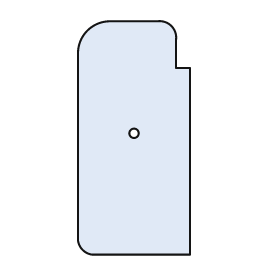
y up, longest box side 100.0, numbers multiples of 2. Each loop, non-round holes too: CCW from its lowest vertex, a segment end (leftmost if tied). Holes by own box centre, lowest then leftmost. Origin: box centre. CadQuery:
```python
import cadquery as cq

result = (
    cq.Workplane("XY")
    .moveTo(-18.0, -50.0)
    .lineTo(24.0, -50.0)
    .lineTo(24.0, 30.0)
    .lineTo(18.0, 30.0)
    .lineTo(18.0, 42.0)
    .threePointArc((16.0, 48.0), (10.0, 50.0))
    .lineTo(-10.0, 50.0)
    .threePointArc((-20.0, 46.0), (-24.0, 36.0))
    .lineTo(-24.0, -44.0)
    .threePointArc((-22.0, -48.0), (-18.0, -50.0))
    .close()
    .moveTo(0.0, 2.0)
    .circle(2.0)
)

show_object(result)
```